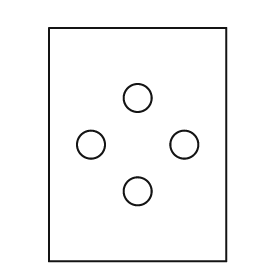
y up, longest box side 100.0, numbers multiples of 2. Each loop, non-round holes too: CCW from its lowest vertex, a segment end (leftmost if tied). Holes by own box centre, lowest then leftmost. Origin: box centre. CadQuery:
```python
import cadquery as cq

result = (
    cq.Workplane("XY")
    .moveTo(-38.0, -50.0)
    .lineTo(38.0, -50.0)
    .lineTo(38.0, 50.0)
    .lineTo(-38.0, 50.0)
    .close()
    .moveTo(0.0, -20.0)
    .circle(6.0)
    .moveTo(-20.0, 0.0)
    .circle(6.0)
    .moveTo(20.0, 0.0)
    .circle(6.0)
    .moveTo(0.0, 20.0)
    .circle(6.0)
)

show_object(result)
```